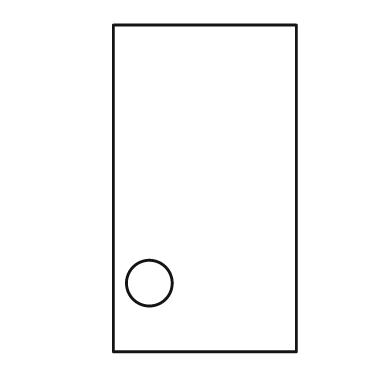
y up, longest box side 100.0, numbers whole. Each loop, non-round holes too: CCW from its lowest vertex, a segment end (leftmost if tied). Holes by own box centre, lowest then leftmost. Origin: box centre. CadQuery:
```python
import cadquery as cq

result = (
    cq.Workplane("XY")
    .moveTo(-28.0, -50.0)
    .lineTo(28.0, -50.0)
    .lineTo(28.0, 50.0)
    .lineTo(-28.0, 50.0)
    .close()
    .moveTo(-17.0, -29.0)
    .circle(7.0)
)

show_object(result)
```